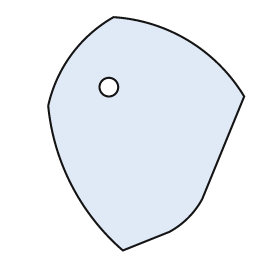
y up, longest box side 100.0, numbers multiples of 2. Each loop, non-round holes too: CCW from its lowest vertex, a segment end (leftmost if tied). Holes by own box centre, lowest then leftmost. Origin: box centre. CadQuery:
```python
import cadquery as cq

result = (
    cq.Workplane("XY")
    .moveTo(-10.0, -50.0)
    .lineTo(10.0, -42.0)
    .threePointArc((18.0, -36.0), (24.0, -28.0))
    .lineTo(42.0, 16.0)
    .threePointArc((18.0, 40.0), (-14.0, 50.0))
    .threePointArc((-32.0, 34.0), (-42.0, 12.0))
    .threePointArc((-32.0, -22.0), (-10.0, -50.0))
    .close()
    .moveTo(-16.0, 20.0)
    .circle(4.0)
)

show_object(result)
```